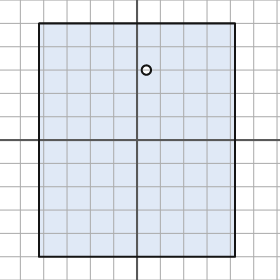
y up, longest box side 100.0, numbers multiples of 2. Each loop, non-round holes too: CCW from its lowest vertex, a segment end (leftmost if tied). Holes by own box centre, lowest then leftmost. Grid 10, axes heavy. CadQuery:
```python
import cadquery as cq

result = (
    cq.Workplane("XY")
    .moveTo(-42.0, -50.0)
    .lineTo(42.0, -50.0)
    .lineTo(42.0, 50.0)
    .lineTo(-42.0, 50.0)
    .close()
    .moveTo(4.0, 30.0)
    .circle(2.0)
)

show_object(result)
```